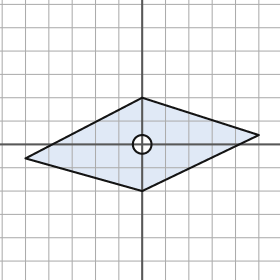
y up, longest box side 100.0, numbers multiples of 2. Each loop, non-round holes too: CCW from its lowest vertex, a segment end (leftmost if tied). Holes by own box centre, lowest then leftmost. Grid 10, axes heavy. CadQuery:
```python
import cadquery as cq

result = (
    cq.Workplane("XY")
    .moveTo(0.0, -20.0)
    .lineTo(50.0, 4.0)
    .lineTo(0.0, 20.0)
    .lineTo(-50.0, -6.0)
    .close()
    .moveTo(0.0, 0.0)
    .circle(4.0)
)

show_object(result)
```